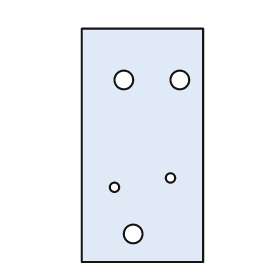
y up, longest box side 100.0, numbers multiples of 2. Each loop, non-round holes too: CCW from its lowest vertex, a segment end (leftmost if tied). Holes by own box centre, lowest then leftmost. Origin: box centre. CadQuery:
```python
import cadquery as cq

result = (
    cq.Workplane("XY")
    .moveTo(-26.0, -50.0)
    .lineTo(26.0, -50.0)
    .lineTo(26.0, 50.0)
    .lineTo(-26.0, 50.0)
    .close()
    .moveTo(-4.0, -38.0)
    .circle(4.0)
    .moveTo(-12.0, -18.0)
    .circle(2.0)
    .moveTo(12.0, -14.0)
    .circle(2.0)
    .moveTo(-8.0, 28.0)
    .circle(4.0)
    .moveTo(16.0, 28.0)
    .circle(4.0)
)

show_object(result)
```